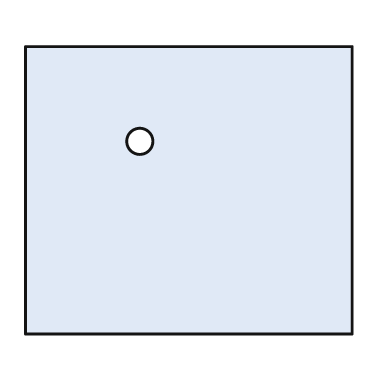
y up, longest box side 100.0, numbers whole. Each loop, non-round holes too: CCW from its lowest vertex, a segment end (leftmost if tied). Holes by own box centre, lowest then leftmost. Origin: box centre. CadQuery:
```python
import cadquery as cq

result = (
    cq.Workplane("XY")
    .moveTo(-50.0, -44.0)
    .lineTo(50.0, -44.0)
    .lineTo(50.0, 44.0)
    .lineTo(-50.0, 44.0)
    .close()
    .moveTo(-15.0, 15.0)
    .circle(4.0)
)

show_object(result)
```